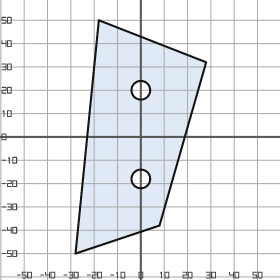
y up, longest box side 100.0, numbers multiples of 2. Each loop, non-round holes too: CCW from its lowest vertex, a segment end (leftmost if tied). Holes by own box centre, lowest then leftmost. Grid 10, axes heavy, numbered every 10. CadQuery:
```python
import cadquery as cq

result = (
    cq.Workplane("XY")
    .moveTo(-28.0, -50.0)
    .lineTo(8.0, -38.0)
    .lineTo(28.0, 32.0)
    .lineTo(-18.0, 50.0)
    .close()
    .moveTo(0.0, -18.0)
    .circle(4.0)
    .moveTo(0.0, 20.0)
    .circle(4.0)
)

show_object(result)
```